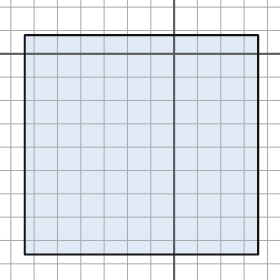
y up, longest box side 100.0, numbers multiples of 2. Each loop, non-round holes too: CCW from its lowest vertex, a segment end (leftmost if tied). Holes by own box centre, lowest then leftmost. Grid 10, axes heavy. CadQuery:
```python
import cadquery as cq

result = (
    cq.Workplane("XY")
    .moveTo(-64.0, -86.0)
    .lineTo(36.0, -86.0)
    .lineTo(36.0, 8.0)
    .lineTo(-64.0, 8.0)
    .close()
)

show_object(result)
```